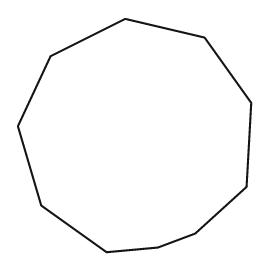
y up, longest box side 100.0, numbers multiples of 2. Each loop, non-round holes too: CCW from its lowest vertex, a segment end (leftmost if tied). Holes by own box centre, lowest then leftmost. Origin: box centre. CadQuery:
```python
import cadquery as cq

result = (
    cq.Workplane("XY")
    .moveTo(-12.0, -50.0)
    .lineTo(10.0, -48.0)
    .lineTo(26.0, -42.0)
    .lineTo(48.0, -22.0)
    .lineTo(50.0, 14.0)
    .lineTo(30.0, 42.0)
    .lineTo(-4.0, 50.0)
    .lineTo(-36.0, 34.0)
    .lineTo(-50.0, 4.0)
    .lineTo(-40.0, -30.0)
    .close()
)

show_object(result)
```